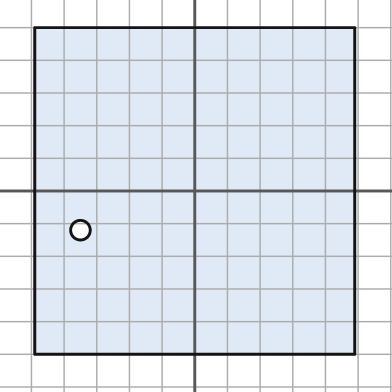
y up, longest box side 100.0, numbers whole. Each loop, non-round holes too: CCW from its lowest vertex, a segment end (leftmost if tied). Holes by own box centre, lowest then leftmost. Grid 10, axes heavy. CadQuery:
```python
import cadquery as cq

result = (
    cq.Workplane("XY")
    .moveTo(-49.0, -50.0)
    .lineTo(49.0, -50.0)
    .lineTo(49.0, 50.0)
    .lineTo(-49.0, 50.0)
    .close()
    .moveTo(-35.0, -12.0)
    .circle(3.0)
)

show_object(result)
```